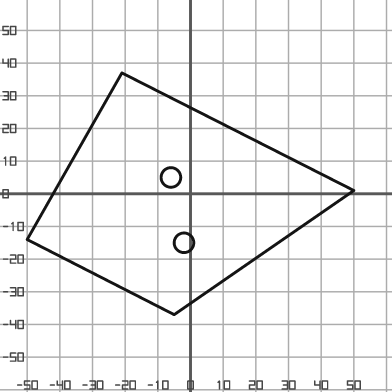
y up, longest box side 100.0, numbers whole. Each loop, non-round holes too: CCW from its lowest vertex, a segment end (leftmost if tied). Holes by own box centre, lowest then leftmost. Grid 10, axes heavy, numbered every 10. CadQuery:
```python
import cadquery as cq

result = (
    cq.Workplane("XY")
    .moveTo(-5.0, -37.0)
    .lineTo(50.0, 1.0)
    .lineTo(-21.0, 37.0)
    .lineTo(-50.0, -14.0)
    .close()
    .moveTo(-2.0, -15.0)
    .circle(3.0)
    .moveTo(-6.0, 5.0)
    .circle(3.0)
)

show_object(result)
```